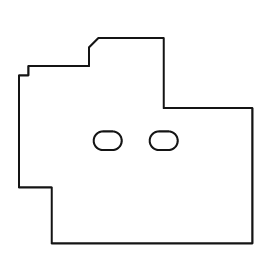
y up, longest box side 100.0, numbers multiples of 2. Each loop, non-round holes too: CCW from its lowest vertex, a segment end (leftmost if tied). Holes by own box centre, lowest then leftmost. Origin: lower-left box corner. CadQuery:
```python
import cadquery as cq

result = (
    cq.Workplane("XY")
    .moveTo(14.0, 0.0)
    .lineTo(100.0, 0.0)
    .lineTo(100.0, 58.0)
    .lineTo(62.0, 58.0)
    .lineTo(62.0, 88.0)
    .lineTo(34.0, 88.0)
    .lineTo(30.0, 84.0)
    .lineTo(30.0, 76.0)
    .lineTo(4.0, 76.0)
    .lineTo(4.0, 72.0)
    .lineTo(0.0, 72.0)
    .lineTo(0.0, 24.0)
    .lineTo(14.0, 24.0)
    .close()
    .moveTo(36.0, 40.0)
    .lineTo(40.0, 40.0)
    .threePointArc((44.0, 44.0), (40.0, 48.0))
    .lineTo(36.0, 48.0)
    .threePointArc((32.0, 44.0), (36.0, 40.0))
    .close()
    .moveTo(60.0, 40.0)
    .lineTo(64.0, 40.0)
    .threePointArc((68.0, 44.0), (64.0, 48.0))
    .lineTo(60.0, 48.0)
    .threePointArc((56.0, 44.0), (60.0, 40.0))
    .close()
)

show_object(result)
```